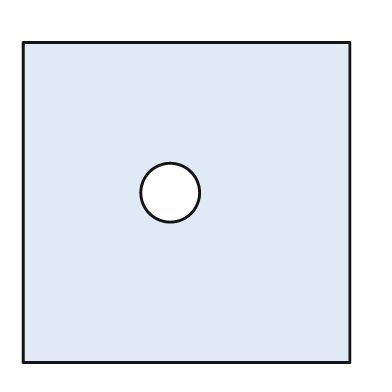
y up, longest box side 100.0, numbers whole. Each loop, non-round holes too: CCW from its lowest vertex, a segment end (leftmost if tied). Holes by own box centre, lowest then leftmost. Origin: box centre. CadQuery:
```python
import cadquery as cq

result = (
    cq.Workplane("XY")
    .moveTo(-50.0, -49.0)
    .lineTo(50.0, -49.0)
    .lineTo(50.0, 49.0)
    .lineTo(-50.0, 49.0)
    .close()
    .moveTo(-5.0, 3.0)
    .circle(9.0)
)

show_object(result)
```